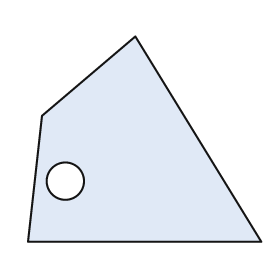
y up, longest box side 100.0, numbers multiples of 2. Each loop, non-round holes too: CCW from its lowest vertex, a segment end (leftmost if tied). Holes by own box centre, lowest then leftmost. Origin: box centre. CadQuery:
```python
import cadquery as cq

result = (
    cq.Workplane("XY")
    .moveTo(-50.0, -44.0)
    .lineTo(50.0, -44.0)
    .lineTo(-4.0, 44.0)
    .lineTo(-44.0, 10.0)
    .close()
    .moveTo(-34.0, -18.0)
    .circle(8.0)
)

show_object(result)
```